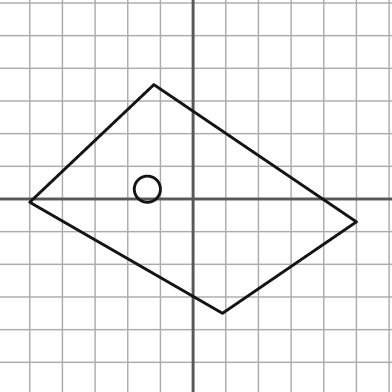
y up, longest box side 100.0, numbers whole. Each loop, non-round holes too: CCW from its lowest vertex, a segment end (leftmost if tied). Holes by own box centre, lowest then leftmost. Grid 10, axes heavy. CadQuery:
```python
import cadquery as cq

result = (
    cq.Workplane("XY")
    .moveTo(9.0, -35.0)
    .lineTo(50.0, -7.0)
    .lineTo(-12.0, 35.0)
    .lineTo(-50.0, -1.0)
    .close()
    .moveTo(-14.0, 3.0)
    .circle(4.0)
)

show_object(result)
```